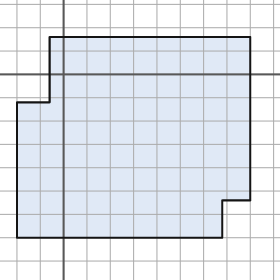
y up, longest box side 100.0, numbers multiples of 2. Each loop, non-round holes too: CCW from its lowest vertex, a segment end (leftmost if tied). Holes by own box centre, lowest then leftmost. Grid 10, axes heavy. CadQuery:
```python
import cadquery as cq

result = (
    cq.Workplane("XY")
    .moveTo(-20.0, -70.0)
    .lineTo(68.0, -70.0)
    .lineTo(68.0, -54.0)
    .lineTo(80.0, -54.0)
    .lineTo(80.0, 16.0)
    .lineTo(-6.0, 16.0)
    .lineTo(-6.0, -12.0)
    .lineTo(-20.0, -12.0)
    .close()
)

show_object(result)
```